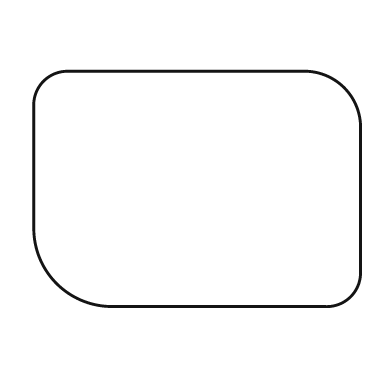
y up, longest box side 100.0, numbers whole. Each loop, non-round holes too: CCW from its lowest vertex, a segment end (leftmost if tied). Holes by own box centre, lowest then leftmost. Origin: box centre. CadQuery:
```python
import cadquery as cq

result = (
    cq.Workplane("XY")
    .moveTo(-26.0, -36.0)
    .lineTo(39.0, -36.0)
    .threePointArc((47.0, -33.0), (50.0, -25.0))
    .lineTo(50.0, 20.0)
    .threePointArc((45.0, 31.0), (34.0, 36.0))
    .lineTo(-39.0, 36.0)
    .threePointArc((-47.0, 33.0), (-50.0, 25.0))
    .lineTo(-50.0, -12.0)
    .threePointArc((-43.0, -29.0), (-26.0, -36.0))
    .close()
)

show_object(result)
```